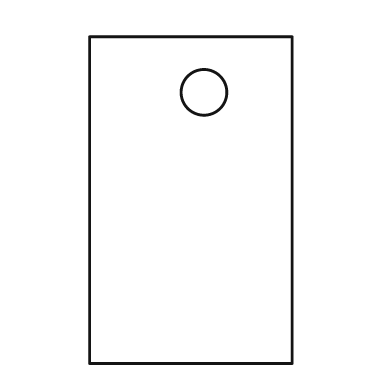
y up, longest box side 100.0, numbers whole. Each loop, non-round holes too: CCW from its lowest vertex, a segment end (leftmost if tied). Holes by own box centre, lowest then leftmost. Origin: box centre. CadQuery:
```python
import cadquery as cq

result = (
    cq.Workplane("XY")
    .moveTo(-31.0, -50.0)
    .lineTo(31.0, -50.0)
    .lineTo(31.0, 50.0)
    .lineTo(-31.0, 50.0)
    .close()
    .moveTo(4.0, 33.0)
    .circle(7.0)
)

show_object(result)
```